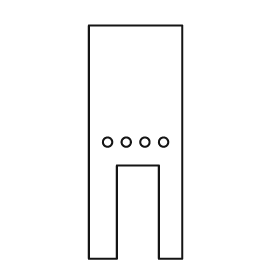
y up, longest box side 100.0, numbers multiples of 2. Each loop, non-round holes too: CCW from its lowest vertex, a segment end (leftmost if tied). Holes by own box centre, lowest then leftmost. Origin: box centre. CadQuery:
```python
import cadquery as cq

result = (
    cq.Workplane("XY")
    .moveTo(-20.0, -50.0)
    .lineTo(-8.0, -50.0)
    .lineTo(-8.0, -10.0)
    .lineTo(10.0, -10.0)
    .lineTo(10.0, -50.0)
    .lineTo(20.0, -50.0)
    .lineTo(20.0, 50.0)
    .lineTo(-20.0, 50.0)
    .close()
    .moveTo(-12.0, 0.0)
    .circle(2.0)
    .moveTo(-4.0, 0.0)
    .circle(2.0)
    .moveTo(4.0, 0.0)
    .circle(2.0)
    .moveTo(12.0, 0.0)
    .circle(2.0)
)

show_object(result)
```